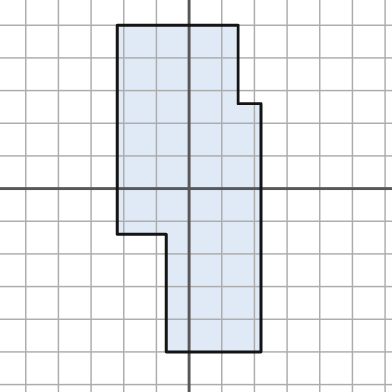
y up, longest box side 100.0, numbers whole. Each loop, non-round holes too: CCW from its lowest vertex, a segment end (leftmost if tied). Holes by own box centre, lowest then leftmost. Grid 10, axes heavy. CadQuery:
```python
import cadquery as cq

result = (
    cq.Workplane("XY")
    .moveTo(-7.0, -50.0)
    .lineTo(22.0, -50.0)
    .lineTo(22.0, 26.0)
    .lineTo(15.0, 26.0)
    .lineTo(15.0, 50.0)
    .lineTo(-22.0, 50.0)
    .lineTo(-22.0, -14.0)
    .lineTo(-7.0, -14.0)
    .close()
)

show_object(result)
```